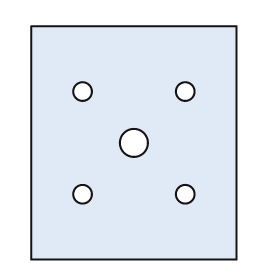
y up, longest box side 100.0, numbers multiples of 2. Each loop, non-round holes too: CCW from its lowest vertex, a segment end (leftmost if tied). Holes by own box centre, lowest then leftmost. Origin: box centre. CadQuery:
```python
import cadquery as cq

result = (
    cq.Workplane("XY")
    .moveTo(-44.0, -50.0)
    .lineTo(44.0, -50.0)
    .lineTo(44.0, 50.0)
    .lineTo(-44.0, 50.0)
    .close()
    .moveTo(-22.0, -22.0)
    .circle(4.0)
    .moveTo(22.0, -22.0)
    .circle(4.0)
    .moveTo(0.0, 0.0)
    .circle(6.0)
    .moveTo(-22.0, 22.0)
    .circle(4.0)
    .moveTo(22.0, 22.0)
    .circle(4.0)
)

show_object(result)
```